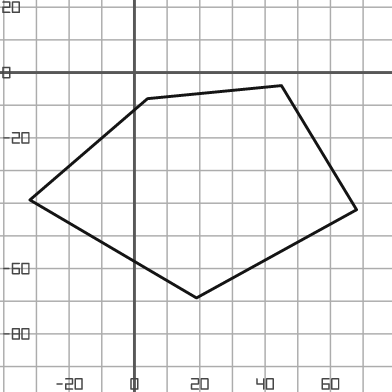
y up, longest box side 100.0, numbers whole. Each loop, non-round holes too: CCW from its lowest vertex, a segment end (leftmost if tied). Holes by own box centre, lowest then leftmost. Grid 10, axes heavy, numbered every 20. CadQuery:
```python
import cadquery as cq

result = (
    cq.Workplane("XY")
    .moveTo(19.0, -69.0)
    .lineTo(68.0, -42.0)
    .lineTo(45.0, -4.0)
    .lineTo(4.0, -8.0)
    .lineTo(-32.0, -39.0)
    .close()
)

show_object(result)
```